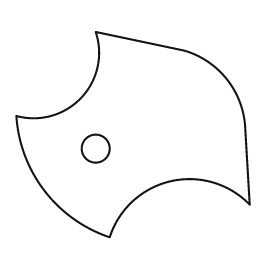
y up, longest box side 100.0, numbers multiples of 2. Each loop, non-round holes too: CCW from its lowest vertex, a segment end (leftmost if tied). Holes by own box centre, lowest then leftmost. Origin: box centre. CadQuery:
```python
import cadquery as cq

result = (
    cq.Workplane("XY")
    .moveTo(-10.0, -44.0)
    .threePointArc((16.0, -20.0), (50.0, -30.0))
    .lineTo(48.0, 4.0)
    .threePointArc((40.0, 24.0), (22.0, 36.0))
    .lineTo(-16.0, 44.0)
    .threePointArc((-22.0, 16.0), (-50.0, 8.0))
    .threePointArc((-38.0, -24.0), (-10.0, -44.0))
    .close()
    .moveTo(-16.0, -6.0)
    .circle(6.0)
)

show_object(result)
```